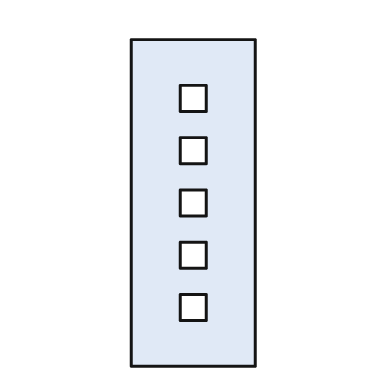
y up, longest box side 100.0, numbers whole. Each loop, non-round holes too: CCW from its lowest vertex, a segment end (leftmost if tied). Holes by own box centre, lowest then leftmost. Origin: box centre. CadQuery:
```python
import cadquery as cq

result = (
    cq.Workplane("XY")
    .moveTo(-19.0, -50.0)
    .lineTo(19.0, -50.0)
    .lineTo(19.0, 50.0)
    .lineTo(-19.0, 50.0)
    .close()
    .moveTo(-4.0, -36.0)
    .lineTo(4.0, -36.0)
    .lineTo(4.0, -28.0)
    .lineTo(-4.0, -28.0)
    .close()
    .moveTo(-4.0, -20.0)
    .lineTo(4.0, -20.0)
    .lineTo(4.0, -12.0)
    .lineTo(-4.0, -12.0)
    .close()
    .moveTo(-4.0, -4.0)
    .lineTo(4.0, -4.0)
    .lineTo(4.0, 4.0)
    .lineTo(-4.0, 4.0)
    .close()
    .moveTo(-4.0, 12.0)
    .lineTo(4.0, 12.0)
    .lineTo(4.0, 20.0)
    .lineTo(-4.0, 20.0)
    .close()
    .moveTo(-4.0, 28.0)
    .lineTo(4.0, 28.0)
    .lineTo(4.0, 36.0)
    .lineTo(-4.0, 36.0)
    .close()
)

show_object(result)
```